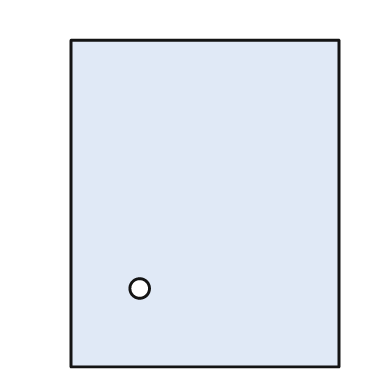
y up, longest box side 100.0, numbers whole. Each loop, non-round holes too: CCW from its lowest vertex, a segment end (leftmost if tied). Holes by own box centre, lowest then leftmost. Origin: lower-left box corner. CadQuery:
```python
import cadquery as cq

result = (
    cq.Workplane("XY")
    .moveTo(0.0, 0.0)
    .lineTo(82.0, 0.0)
    .lineTo(82.0, 100.0)
    .lineTo(0.0, 100.0)
    .close()
    .moveTo(21.0, 24.0)
    .circle(3.0)
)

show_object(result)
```